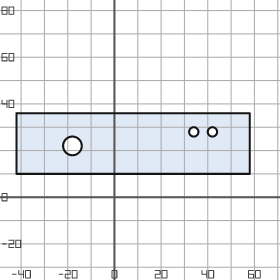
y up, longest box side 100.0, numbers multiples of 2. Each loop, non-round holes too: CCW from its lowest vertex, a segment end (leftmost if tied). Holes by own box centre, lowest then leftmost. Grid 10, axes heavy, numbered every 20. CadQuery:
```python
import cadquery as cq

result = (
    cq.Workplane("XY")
    .moveTo(-42.0, 10.0)
    .lineTo(58.0, 10.0)
    .lineTo(58.0, 36.0)
    .lineTo(-42.0, 36.0)
    .close()
    .moveTo(-18.0, 22.0)
    .circle(4.0)
    .moveTo(34.0, 28.0)
    .circle(2.0)
    .moveTo(42.0, 28.0)
    .circle(2.0)
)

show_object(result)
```